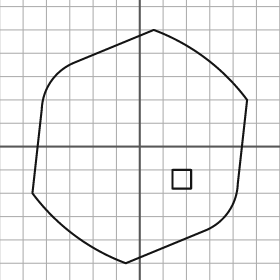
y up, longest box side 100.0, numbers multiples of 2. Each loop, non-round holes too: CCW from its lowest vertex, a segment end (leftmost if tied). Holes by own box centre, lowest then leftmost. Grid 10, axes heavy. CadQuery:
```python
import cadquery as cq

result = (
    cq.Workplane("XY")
    .moveTo(-6.0, -50.0)
    .lineTo(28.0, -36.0)
    .threePointArc((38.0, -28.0), (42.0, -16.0))
    .lineTo(46.0, 20.0)
    .threePointArc((28.0, 38.0), (6.0, 50.0))
    .lineTo(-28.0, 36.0)
    .threePointArc((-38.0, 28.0), (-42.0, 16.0))
    .lineTo(-46.0, -20.0)
    .threePointArc((-28.0, -38.0), (-6.0, -50.0))
    .close()
    .moveTo(14.0, -18.0)
    .lineTo(22.0, -18.0)
    .lineTo(22.0, -10.0)
    .lineTo(14.0, -10.0)
    .close()
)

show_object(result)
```